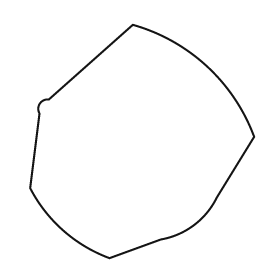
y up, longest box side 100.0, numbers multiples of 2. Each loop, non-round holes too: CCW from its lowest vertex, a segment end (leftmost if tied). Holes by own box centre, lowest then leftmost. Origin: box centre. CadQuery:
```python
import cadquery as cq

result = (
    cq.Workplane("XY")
    .moveTo(-14.0, -50.0)
    .lineTo(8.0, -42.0)
    .threePointArc((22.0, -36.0), (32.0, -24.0))
    .lineTo(48.0, 2.0)
    .threePointArc((28.0, 32.0), (-4.0, 50.0))
    .lineTo(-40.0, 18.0)
    .threePointArc((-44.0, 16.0), (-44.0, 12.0))
    .lineTo(-48.0, -20.0)
    .threePointArc((-34.0, -38.0), (-14.0, -50.0))
    .close()
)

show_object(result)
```